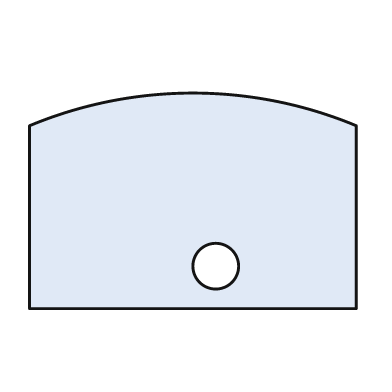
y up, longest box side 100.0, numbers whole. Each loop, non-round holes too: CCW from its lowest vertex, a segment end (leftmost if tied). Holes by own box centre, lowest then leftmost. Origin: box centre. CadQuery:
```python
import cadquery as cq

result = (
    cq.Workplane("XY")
    .moveTo(-50.0, -33.0)
    .lineTo(50.0, -33.0)
    .lineTo(50.0, 23.0)
    .threePointArc((0.0, 33.0), (-50.0, 23.0))
    .close()
    .moveTo(7.0, -20.0)
    .circle(7.0)
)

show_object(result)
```